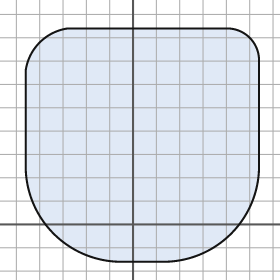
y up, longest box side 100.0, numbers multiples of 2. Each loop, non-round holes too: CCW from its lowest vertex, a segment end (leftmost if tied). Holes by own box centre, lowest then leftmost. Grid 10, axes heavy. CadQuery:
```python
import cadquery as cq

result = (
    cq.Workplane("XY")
    .moveTo(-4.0, -16.0)
    .lineTo(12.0, -16.0)
    .threePointArc((42.0, -4.0), (54.0, 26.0))
    .lineTo(54.0, 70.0)
    .threePointArc((50.0, 80.0), (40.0, 84.0))
    .lineTo(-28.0, 84.0)
    .threePointArc((-40.0, 78.0), (-46.0, 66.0))
    .lineTo(-46.0, 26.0)
    .threePointArc((-34.0, -4.0), (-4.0, -16.0))
    .close()
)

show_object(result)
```